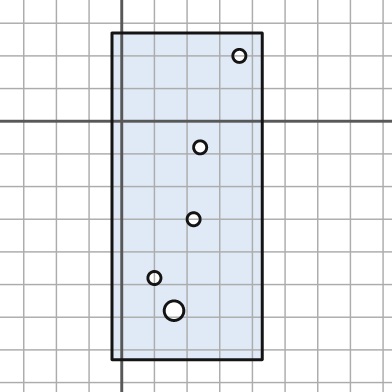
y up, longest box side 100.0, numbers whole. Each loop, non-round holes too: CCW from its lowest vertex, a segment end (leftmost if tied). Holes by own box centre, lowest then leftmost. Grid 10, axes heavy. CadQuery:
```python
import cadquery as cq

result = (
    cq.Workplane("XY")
    .moveTo(-3.0, -73.0)
    .lineTo(43.0, -73.0)
    .lineTo(43.0, 27.0)
    .lineTo(-3.0, 27.0)
    .close()
    .moveTo(16.0, -58.0)
    .circle(3.0)
    .moveTo(10.0, -48.0)
    .circle(2.0)
    .moveTo(22.0, -30.0)
    .circle(2.0)
    .moveTo(24.0, -8.0)
    .circle(2.0)
    .moveTo(36.0, 20.0)
    .circle(2.0)
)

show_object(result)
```